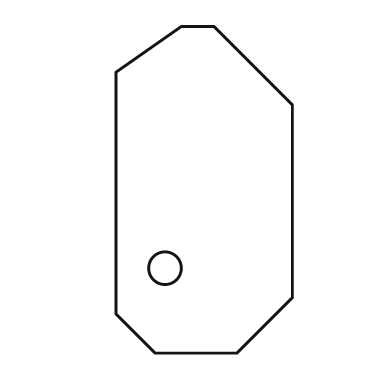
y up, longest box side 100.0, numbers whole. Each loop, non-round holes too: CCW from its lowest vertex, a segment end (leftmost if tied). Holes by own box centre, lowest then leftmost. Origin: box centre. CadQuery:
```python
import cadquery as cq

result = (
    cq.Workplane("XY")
    .moveTo(-15.0, -50.0)
    .lineTo(10.0, -50.0)
    .lineTo(27.0, -33.0)
    .lineTo(27.0, 26.0)
    .lineTo(3.0, 50.0)
    .lineTo(-7.0, 50.0)
    .lineTo(-27.0, 36.0)
    .lineTo(-27.0, -38.0)
    .close()
    .moveTo(-12.0, -24.0)
    .circle(5.0)
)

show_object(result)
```